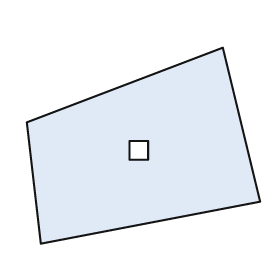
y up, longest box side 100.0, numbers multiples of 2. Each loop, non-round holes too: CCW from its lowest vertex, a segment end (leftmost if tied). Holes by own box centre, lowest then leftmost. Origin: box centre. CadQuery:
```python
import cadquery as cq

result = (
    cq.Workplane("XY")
    .moveTo(-44.0, -42.0)
    .lineTo(50.0, -24.0)
    .lineTo(34.0, 42.0)
    .lineTo(-50.0, 10.0)
    .close()
    .moveTo(-6.0, -6.0)
    .lineTo(2.0, -6.0)
    .lineTo(2.0, 2.0)
    .lineTo(-6.0, 2.0)
    .close()
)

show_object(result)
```